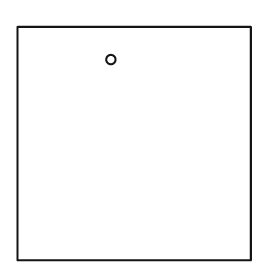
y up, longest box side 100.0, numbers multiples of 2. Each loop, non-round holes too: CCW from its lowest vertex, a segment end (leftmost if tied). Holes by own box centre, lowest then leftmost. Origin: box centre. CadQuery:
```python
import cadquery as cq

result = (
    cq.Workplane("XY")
    .moveTo(-50.0, -50.0)
    .lineTo(50.0, -50.0)
    .lineTo(50.0, 50.0)
    .lineTo(-50.0, 50.0)
    .close()
    .moveTo(-10.0, 36.0)
    .circle(2.0)
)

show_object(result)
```